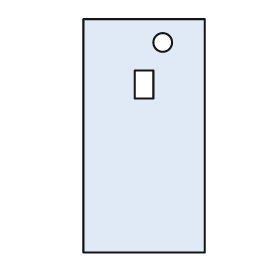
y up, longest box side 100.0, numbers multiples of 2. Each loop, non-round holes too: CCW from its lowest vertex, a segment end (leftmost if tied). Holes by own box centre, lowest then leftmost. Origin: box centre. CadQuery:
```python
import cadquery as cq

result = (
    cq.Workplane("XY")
    .moveTo(-26.0, -50.0)
    .lineTo(26.0, -50.0)
    .lineTo(26.0, 50.0)
    .lineTo(-26.0, 50.0)
    .close()
    .moveTo(-4.0, 16.0)
    .lineTo(4.0, 16.0)
    .lineTo(4.0, 28.0)
    .lineTo(-4.0, 28.0)
    .close()
    .moveTo(8.0, 40.0)
    .circle(4.0)
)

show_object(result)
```